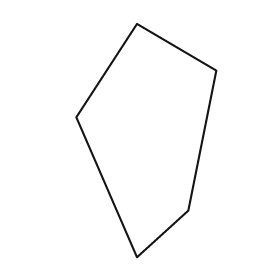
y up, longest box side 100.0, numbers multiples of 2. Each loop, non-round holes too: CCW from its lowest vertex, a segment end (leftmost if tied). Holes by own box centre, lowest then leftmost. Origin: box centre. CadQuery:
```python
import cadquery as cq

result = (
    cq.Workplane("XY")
    .moveTo(-4.0, -50.0)
    .lineTo(18.0, -30.0)
    .lineTo(30.0, 30.0)
    .lineTo(-4.0, 50.0)
    .lineTo(-30.0, 10.0)
    .close()
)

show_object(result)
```